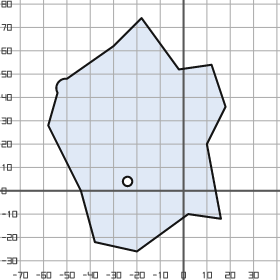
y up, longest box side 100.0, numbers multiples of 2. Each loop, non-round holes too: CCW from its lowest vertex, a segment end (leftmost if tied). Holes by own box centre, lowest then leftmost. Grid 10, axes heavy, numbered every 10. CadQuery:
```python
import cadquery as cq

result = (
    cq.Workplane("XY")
    .moveTo(-20.0, -26.0)
    .lineTo(2.0, -10.0)
    .lineTo(16.0, -12.0)
    .lineTo(10.0, 20.0)
    .lineTo(18.0, 36.0)
    .lineTo(12.0, 54.0)
    .lineTo(-2.0, 52.0)
    .lineTo(-18.0, 74.0)
    .lineTo(-30.0, 62.0)
    .lineTo(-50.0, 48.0)
    .threePointArc((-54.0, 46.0), (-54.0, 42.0))
    .lineTo(-58.0, 28.0)
    .lineTo(-44.0, 0.0)
    .lineTo(-38.0, -22.0)
    .close()
    .moveTo(-24.0, 4.0)
    .circle(2.0)
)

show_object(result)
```